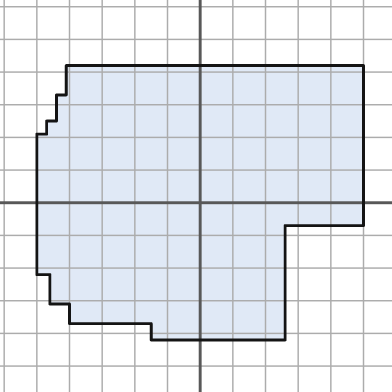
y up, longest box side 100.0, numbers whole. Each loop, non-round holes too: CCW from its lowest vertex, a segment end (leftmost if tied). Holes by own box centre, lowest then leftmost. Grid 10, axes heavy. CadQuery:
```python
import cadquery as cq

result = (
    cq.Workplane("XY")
    .moveTo(-15.0, -42.0)
    .lineTo(26.0, -42.0)
    .lineTo(26.0, -7.0)
    .lineTo(50.0, -7.0)
    .lineTo(50.0, 42.0)
    .lineTo(-41.0, 42.0)
    .lineTo(-41.0, 33.0)
    .lineTo(-44.0, 33.0)
    .lineTo(-44.0, 25.0)
    .lineTo(-47.0, 25.0)
    .lineTo(-47.0, 21.0)
    .lineTo(-50.0, 21.0)
    .lineTo(-50.0, -22.0)
    .lineTo(-46.0, -22.0)
    .lineTo(-46.0, -31.0)
    .lineTo(-40.0, -31.0)
    .lineTo(-40.0, -37.0)
    .lineTo(-15.0, -37.0)
    .close()
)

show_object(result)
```